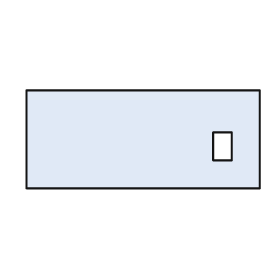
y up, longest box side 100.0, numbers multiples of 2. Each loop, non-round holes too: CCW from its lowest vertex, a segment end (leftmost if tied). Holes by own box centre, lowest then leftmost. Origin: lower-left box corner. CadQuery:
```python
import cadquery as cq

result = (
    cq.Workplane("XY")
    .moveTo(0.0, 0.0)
    .lineTo(100.0, 0.0)
    .lineTo(100.0, 42.0)
    .lineTo(0.0, 42.0)
    .close()
    .moveTo(80.0, 12.0)
    .lineTo(88.0, 12.0)
    .lineTo(88.0, 24.0)
    .lineTo(80.0, 24.0)
    .close()
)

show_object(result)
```